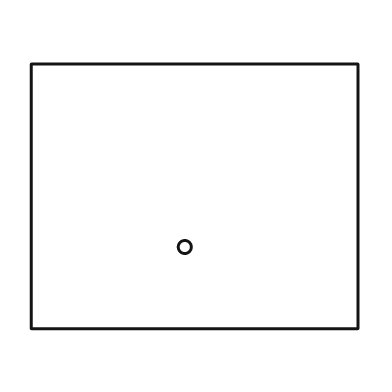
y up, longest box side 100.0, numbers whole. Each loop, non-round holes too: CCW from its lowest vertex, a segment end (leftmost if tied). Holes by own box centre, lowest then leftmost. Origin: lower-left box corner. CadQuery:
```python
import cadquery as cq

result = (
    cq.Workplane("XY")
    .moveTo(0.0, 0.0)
    .lineTo(100.0, 0.0)
    .lineTo(100.0, 81.0)
    .lineTo(0.0, 81.0)
    .close()
    .moveTo(47.0, 25.0)
    .circle(2.0)
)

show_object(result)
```